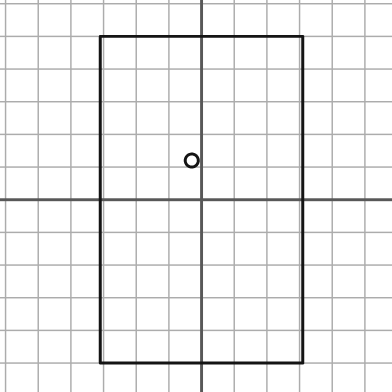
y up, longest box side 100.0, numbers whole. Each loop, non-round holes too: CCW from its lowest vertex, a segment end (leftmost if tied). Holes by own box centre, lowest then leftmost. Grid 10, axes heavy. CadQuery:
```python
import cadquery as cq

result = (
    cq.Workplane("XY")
    .moveTo(-31.0, -50.0)
    .lineTo(31.0, -50.0)
    .lineTo(31.0, 50.0)
    .lineTo(-31.0, 50.0)
    .close()
    .moveTo(-3.0, 12.0)
    .circle(2.0)
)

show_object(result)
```